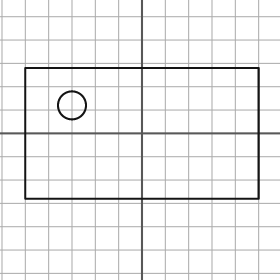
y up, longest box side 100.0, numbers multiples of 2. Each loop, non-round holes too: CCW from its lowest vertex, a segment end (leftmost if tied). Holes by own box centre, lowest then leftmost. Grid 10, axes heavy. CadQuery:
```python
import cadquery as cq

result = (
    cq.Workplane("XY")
    .moveTo(-50.0, -28.0)
    .lineTo(50.0, -28.0)
    .lineTo(50.0, 28.0)
    .lineTo(-50.0, 28.0)
    .close()
    .moveTo(-30.0, 12.0)
    .circle(6.0)
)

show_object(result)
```